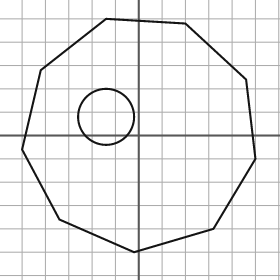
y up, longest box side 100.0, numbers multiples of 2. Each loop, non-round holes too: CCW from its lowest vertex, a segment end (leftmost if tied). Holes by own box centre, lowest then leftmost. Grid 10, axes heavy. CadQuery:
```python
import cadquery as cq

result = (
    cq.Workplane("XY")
    .moveTo(-2.0, -50.0)
    .lineTo(32.0, -40.0)
    .lineTo(50.0, -10.0)
    .lineTo(46.0, 24.0)
    .lineTo(20.0, 48.0)
    .lineTo(-14.0, 50.0)
    .lineTo(-42.0, 28.0)
    .lineTo(-50.0, -6.0)
    .lineTo(-34.0, -36.0)
    .close()
    .moveTo(-14.0, 8.0)
    .circle(12.0)
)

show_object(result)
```